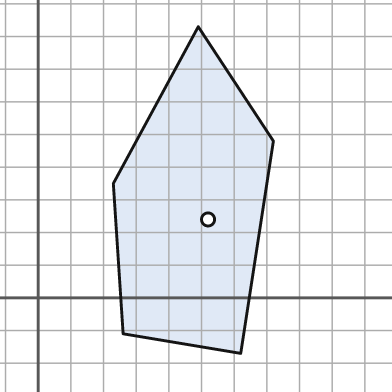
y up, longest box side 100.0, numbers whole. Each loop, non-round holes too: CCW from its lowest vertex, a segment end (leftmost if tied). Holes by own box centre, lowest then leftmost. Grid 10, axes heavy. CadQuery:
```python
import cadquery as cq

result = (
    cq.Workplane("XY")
    .moveTo(62.0, -17.0)
    .lineTo(72.0, 48.0)
    .lineTo(49.0, 83.0)
    .lineTo(23.0, 35.0)
    .lineTo(26.0, -11.0)
    .close()
    .moveTo(52.0, 24.0)
    .circle(2.0)
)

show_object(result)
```